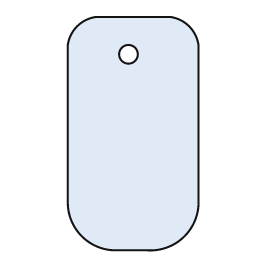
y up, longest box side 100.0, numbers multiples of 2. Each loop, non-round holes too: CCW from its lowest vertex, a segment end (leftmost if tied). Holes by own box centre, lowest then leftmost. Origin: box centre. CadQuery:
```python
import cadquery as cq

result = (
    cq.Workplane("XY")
    .moveTo(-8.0, -50.0)
    .lineTo(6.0, -50.0)
    .threePointArc((22.0, -44.0), (28.0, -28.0))
    .lineTo(28.0, 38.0)
    .threePointArc((24.0, 46.0), (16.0, 50.0))
    .lineTo(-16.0, 50.0)
    .threePointArc((-24.0, 46.0), (-28.0, 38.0))
    .lineTo(-28.0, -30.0)
    .threePointArc((-22.0, -44.0), (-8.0, -50.0))
    .close()
    .moveTo(-2.0, 34.0)
    .circle(4.0)
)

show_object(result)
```